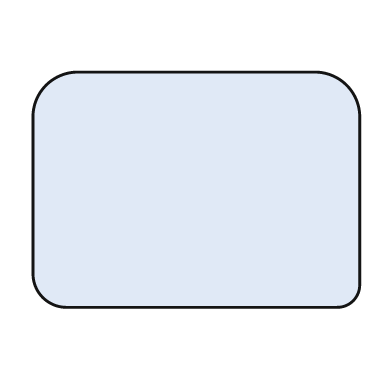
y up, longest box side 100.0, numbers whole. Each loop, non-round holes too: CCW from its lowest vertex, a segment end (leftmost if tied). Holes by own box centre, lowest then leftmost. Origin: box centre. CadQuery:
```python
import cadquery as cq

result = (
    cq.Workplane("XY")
    .moveTo(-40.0, -36.0)
    .lineTo(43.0, -36.0)
    .threePointArc((48.0, -34.0), (50.0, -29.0))
    .lineTo(50.0, 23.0)
    .threePointArc((46.0, 32.0), (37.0, 36.0))
    .lineTo(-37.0, 36.0)
    .threePointArc((-46.0, 32.0), (-50.0, 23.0))
    .lineTo(-50.0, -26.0)
    .threePointArc((-47.0, -33.0), (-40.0, -36.0))
    .close()
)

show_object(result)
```